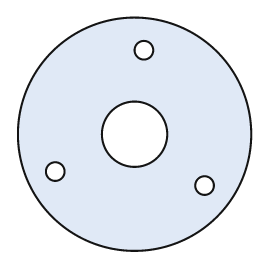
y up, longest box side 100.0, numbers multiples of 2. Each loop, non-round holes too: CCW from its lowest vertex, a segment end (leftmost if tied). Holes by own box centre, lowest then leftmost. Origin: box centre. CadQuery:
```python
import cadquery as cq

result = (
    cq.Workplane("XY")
    .moveTo(0.0, 0.0)
    .circle(50.0)
    .moveTo(30.0, -22.0)
    .circle(4.0)
    .moveTo(-34.0, -16.0)
    .circle(4.0)
    .moveTo(0.0, 0.0)
    .circle(14.0)
    .moveTo(4.0, 36.0)
    .circle(4.0)
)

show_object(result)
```